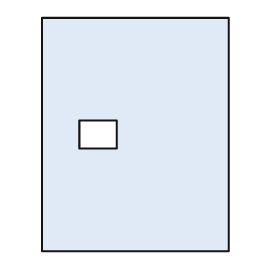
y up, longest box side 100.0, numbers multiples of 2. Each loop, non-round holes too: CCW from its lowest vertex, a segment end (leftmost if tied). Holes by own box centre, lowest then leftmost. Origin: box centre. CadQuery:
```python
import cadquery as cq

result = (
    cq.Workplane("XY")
    .moveTo(-40.0, -50.0)
    .lineTo(40.0, -50.0)
    .lineTo(40.0, 50.0)
    .lineTo(-40.0, 50.0)
    .close()
    .moveTo(-24.0, -6.0)
    .lineTo(-8.0, -6.0)
    .lineTo(-8.0, 6.0)
    .lineTo(-24.0, 6.0)
    .close()
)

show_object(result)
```